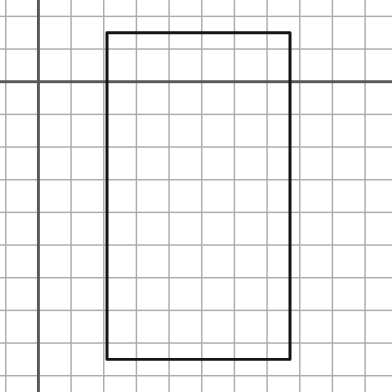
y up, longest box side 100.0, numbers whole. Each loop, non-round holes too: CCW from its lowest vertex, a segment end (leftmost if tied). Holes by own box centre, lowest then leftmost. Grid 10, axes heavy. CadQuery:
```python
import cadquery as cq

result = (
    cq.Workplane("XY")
    .moveTo(21.0, -85.0)
    .lineTo(77.0, -85.0)
    .lineTo(77.0, 15.0)
    .lineTo(21.0, 15.0)
    .close()
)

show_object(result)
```